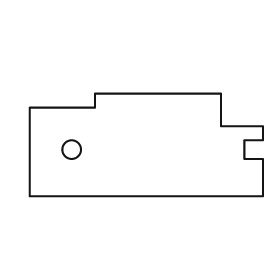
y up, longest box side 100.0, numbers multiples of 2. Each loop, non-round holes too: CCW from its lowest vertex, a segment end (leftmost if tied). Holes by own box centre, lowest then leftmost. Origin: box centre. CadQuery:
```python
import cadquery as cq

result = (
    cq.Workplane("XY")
    .moveTo(-50.0, -22.0)
    .lineTo(50.0, -22.0)
    .lineTo(50.0, -6.0)
    .lineTo(42.0, -6.0)
    .lineTo(42.0, 2.0)
    .lineTo(50.0, 2.0)
    .lineTo(50.0, 8.0)
    .lineTo(32.0, 8.0)
    .lineTo(32.0, 22.0)
    .lineTo(-22.0, 22.0)
    .lineTo(-22.0, 16.0)
    .lineTo(-50.0, 16.0)
    .close()
    .moveTo(-32.0, -2.0)
    .circle(4.0)
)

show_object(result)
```